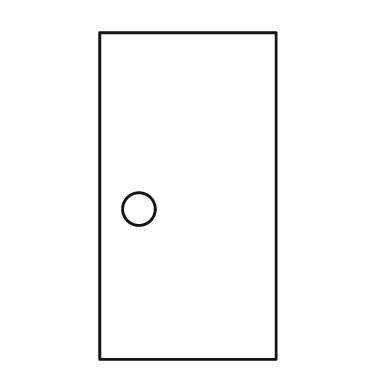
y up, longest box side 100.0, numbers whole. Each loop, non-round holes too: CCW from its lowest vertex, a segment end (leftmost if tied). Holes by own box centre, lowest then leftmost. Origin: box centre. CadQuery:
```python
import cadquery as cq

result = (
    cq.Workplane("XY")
    .moveTo(-27.0, -50.0)
    .lineTo(27.0, -50.0)
    .lineTo(27.0, 50.0)
    .lineTo(-27.0, 50.0)
    .close()
    .moveTo(-15.0, -4.0)
    .circle(5.0)
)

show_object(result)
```